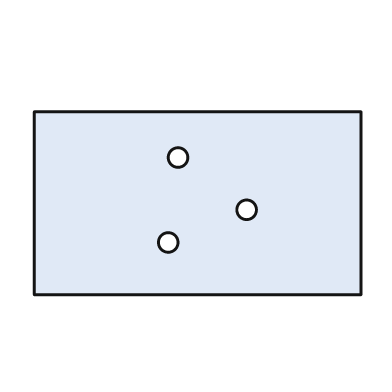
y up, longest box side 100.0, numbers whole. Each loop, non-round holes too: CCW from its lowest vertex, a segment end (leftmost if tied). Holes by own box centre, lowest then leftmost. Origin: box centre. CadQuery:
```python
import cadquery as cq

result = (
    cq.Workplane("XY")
    .moveTo(-50.0, -28.0)
    .lineTo(50.0, -28.0)
    .lineTo(50.0, 28.0)
    .lineTo(-50.0, 28.0)
    .close()
    .moveTo(-9.0, -12.0)
    .circle(3.0)
    .moveTo(15.0, -2.0)
    .circle(3.0)
    .moveTo(-6.0, 14.0)
    .circle(3.0)
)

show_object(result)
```